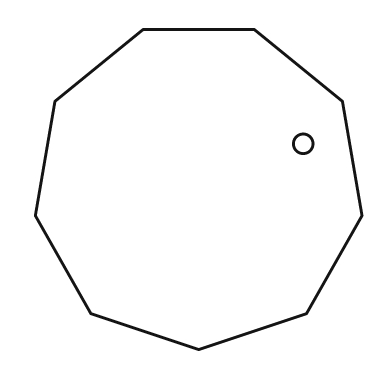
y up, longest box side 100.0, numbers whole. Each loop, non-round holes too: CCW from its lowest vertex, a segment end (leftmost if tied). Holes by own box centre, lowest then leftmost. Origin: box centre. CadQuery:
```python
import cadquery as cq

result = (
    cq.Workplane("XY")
    .moveTo(0.0, -49.0)
    .lineTo(33.0, -38.0)
    .lineTo(50.0, -8.0)
    .lineTo(44.0, 27.0)
    .lineTo(17.0, 49.0)
    .lineTo(-17.0, 49.0)
    .lineTo(-44.0, 27.0)
    .lineTo(-50.0, -8.0)
    .lineTo(-33.0, -38.0)
    .close()
    .moveTo(32.0, 14.0)
    .circle(3.0)
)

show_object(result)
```